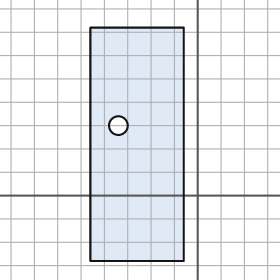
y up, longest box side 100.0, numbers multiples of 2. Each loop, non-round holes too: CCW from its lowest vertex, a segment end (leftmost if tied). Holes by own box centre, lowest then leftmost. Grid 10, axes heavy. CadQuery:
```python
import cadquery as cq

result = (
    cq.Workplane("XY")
    .moveTo(-46.0, -28.0)
    .lineTo(-6.0, -28.0)
    .lineTo(-6.0, 72.0)
    .lineTo(-46.0, 72.0)
    .close()
    .moveTo(-34.0, 30.0)
    .circle(4.0)
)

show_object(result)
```